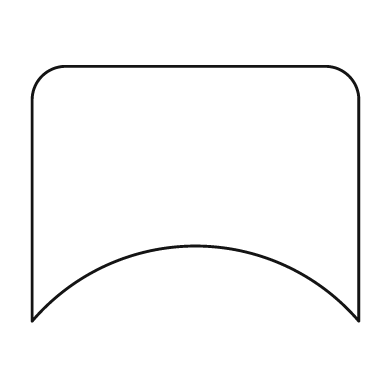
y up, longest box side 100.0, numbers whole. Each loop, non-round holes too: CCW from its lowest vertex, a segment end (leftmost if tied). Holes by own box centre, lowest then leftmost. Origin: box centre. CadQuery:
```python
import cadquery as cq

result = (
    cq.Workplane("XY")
    .moveTo(-50.0, -39.0)
    .threePointArc((0.0, -16.0), (50.0, -39.0))
    .lineTo(50.0, 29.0)
    .threePointArc((47.0, 36.0), (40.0, 39.0))
    .lineTo(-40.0, 39.0)
    .threePointArc((-47.0, 36.0), (-50.0, 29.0))
    .close()
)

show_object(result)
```